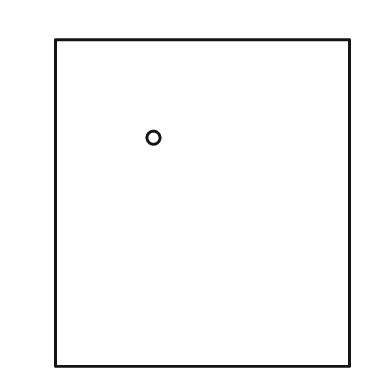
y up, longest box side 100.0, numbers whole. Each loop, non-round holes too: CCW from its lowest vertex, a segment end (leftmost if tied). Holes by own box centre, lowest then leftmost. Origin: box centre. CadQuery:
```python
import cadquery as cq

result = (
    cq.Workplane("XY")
    .moveTo(-45.0, -50.0)
    .lineTo(45.0, -50.0)
    .lineTo(45.0, 50.0)
    .lineTo(-45.0, 50.0)
    .close()
    .moveTo(-15.0, 20.0)
    .circle(2.0)
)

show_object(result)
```